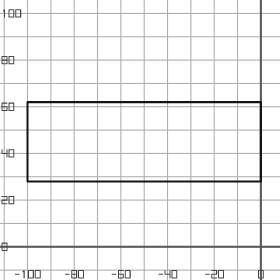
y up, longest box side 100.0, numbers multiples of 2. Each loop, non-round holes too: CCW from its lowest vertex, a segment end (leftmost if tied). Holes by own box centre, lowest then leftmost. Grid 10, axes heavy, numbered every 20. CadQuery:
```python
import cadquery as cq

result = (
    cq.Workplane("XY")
    .moveTo(-100.0, 28.0)
    .lineTo(0.0, 28.0)
    .lineTo(0.0, 62.0)
    .lineTo(-100.0, 62.0)
    .close()
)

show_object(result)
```